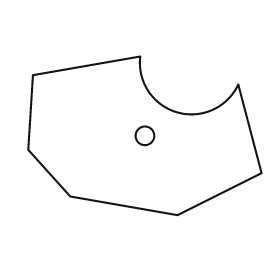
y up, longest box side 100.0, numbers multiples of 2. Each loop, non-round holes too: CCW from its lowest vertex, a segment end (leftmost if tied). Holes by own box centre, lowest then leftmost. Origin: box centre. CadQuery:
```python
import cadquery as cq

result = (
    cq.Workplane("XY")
    .moveTo(14.0, -34.0)
    .lineTo(50.0, -16.0)
    .lineTo(40.0, 22.0)
    .threePointArc((14.0, 10.0), (-2.0, 34.0))
    .lineTo(-48.0, 26.0)
    .lineTo(-50.0, -6.0)
    .lineTo(-32.0, -26.0)
    .close()
    .moveTo(0.0, 0.0)
    .circle(4.0)
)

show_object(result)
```